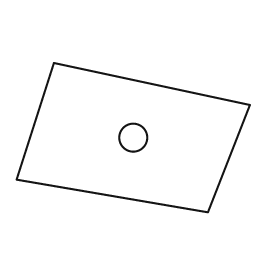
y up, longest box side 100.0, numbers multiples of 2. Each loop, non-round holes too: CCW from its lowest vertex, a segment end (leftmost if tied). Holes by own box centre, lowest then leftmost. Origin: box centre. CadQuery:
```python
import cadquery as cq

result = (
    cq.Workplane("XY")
    .moveTo(32.0, -32.0)
    .lineTo(50.0, 14.0)
    .lineTo(-34.0, 32.0)
    .lineTo(-50.0, -18.0)
    .close()
    .moveTo(0.0, 0.0)
    .circle(6.0)
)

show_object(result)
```